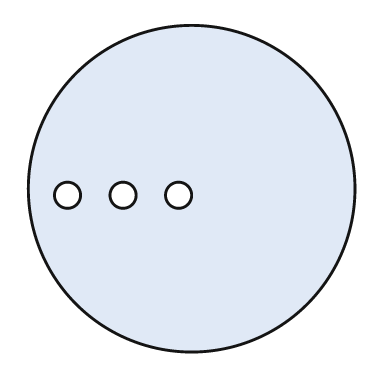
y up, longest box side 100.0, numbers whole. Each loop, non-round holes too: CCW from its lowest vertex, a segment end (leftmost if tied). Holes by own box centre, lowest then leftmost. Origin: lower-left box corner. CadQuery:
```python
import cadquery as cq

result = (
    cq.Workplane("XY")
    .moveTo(50.0, 50.0)
    .circle(50.0)
    .moveTo(12.0, 48.0)
    .circle(4.0)
    .moveTo(29.0, 48.0)
    .circle(4.0)
    .moveTo(46.0, 48.0)
    .circle(4.0)
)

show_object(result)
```